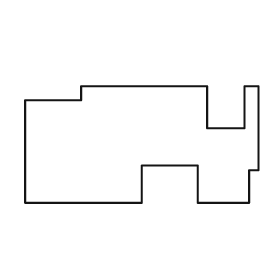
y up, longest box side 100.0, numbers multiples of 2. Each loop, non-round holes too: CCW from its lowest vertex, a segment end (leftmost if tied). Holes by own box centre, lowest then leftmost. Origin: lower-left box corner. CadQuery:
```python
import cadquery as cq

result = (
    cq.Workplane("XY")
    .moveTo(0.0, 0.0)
    .lineTo(50.0, 0.0)
    .lineTo(50.0, 16.0)
    .lineTo(74.0, 16.0)
    .lineTo(74.0, 0.0)
    .lineTo(96.0, 0.0)
    .lineTo(96.0, 14.0)
    .lineTo(100.0, 14.0)
    .lineTo(100.0, 50.0)
    .lineTo(94.0, 50.0)
    .lineTo(94.0, 32.0)
    .lineTo(78.0, 32.0)
    .lineTo(78.0, 50.0)
    .lineTo(24.0, 50.0)
    .lineTo(24.0, 44.0)
    .lineTo(0.0, 44.0)
    .close()
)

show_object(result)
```